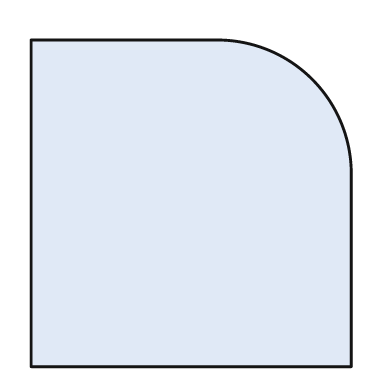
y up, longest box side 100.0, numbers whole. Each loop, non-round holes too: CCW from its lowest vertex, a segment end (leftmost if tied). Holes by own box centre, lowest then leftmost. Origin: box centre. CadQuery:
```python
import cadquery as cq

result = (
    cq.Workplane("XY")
    .moveTo(-49.0, -50.0)
    .lineTo(49.0, -50.0)
    .lineTo(49.0, 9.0)
    .threePointArc((37.0, 38.0), (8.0, 50.0))
    .lineTo(-49.0, 50.0)
    .close()
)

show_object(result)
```